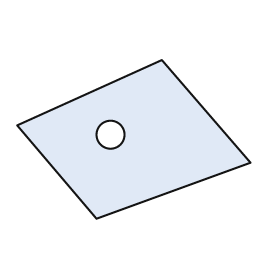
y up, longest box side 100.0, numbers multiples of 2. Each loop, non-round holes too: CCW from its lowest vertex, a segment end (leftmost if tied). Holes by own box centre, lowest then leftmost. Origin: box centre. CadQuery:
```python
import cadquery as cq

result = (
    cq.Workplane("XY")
    .moveTo(-16.0, -34.0)
    .lineTo(50.0, -10.0)
    .lineTo(12.0, 34.0)
    .lineTo(-50.0, 6.0)
    .close()
    .moveTo(-10.0, 2.0)
    .circle(6.0)
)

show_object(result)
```